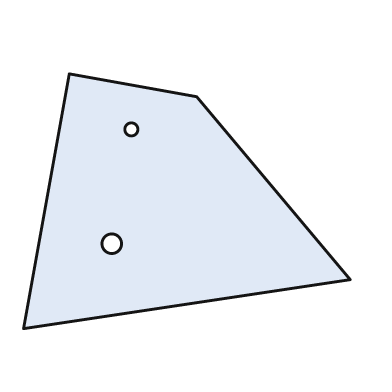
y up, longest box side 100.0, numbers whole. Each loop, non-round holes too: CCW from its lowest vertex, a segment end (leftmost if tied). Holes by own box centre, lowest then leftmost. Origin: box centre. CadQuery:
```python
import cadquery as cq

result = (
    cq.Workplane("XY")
    .moveTo(-50.0, -39.0)
    .lineTo(50.0, -24.0)
    .lineTo(3.0, 32.0)
    .lineTo(-36.0, 39.0)
    .close()
    .moveTo(-23.0, -13.0)
    .circle(3.0)
    .moveTo(-17.0, 22.0)
    .circle(2.0)
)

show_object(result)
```